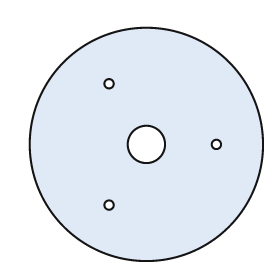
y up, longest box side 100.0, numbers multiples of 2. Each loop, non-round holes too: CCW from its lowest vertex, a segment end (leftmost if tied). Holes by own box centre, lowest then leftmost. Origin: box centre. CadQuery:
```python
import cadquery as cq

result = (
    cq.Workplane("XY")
    .moveTo(0.0, 0.0)
    .circle(50.0)
    .moveTo(-16.0, -26.0)
    .circle(2.0)
    .moveTo(0.0, 0.0)
    .circle(8.0)
    .moveTo(30.0, 0.0)
    .circle(2.0)
    .moveTo(-16.0, 26.0)
    .circle(2.0)
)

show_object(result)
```